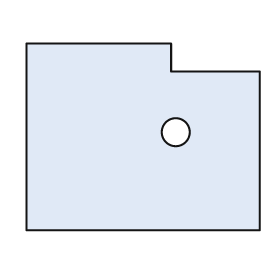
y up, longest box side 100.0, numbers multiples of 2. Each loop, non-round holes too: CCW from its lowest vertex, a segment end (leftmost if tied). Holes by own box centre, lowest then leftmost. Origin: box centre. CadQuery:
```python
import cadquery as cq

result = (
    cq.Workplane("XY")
    .moveTo(-50.0, -40.0)
    .lineTo(50.0, -40.0)
    .lineTo(50.0, 28.0)
    .lineTo(12.0, 28.0)
    .lineTo(12.0, 40.0)
    .lineTo(-50.0, 40.0)
    .close()
    .moveTo(14.0, 2.0)
    .circle(6.0)
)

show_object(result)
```